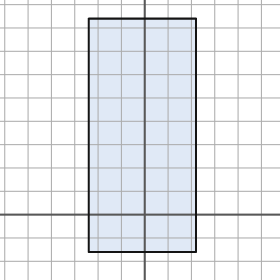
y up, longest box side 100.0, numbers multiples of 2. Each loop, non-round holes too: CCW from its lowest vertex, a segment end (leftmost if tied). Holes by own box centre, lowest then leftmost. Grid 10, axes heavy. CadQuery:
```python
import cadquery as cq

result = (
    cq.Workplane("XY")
    .moveTo(-24.0, -16.0)
    .lineTo(22.0, -16.0)
    .lineTo(22.0, 84.0)
    .lineTo(-24.0, 84.0)
    .close()
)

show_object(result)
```